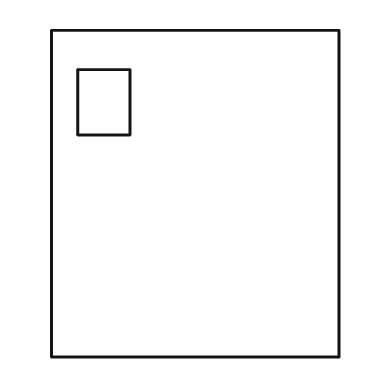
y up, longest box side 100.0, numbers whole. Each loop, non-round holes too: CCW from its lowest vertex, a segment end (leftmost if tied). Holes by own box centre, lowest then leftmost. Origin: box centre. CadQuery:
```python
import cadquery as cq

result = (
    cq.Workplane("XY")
    .moveTo(-44.0, -50.0)
    .lineTo(44.0, -50.0)
    .lineTo(44.0, 50.0)
    .lineTo(-44.0, 50.0)
    .close()
    .moveTo(-36.0, 18.0)
    .lineTo(-20.0, 18.0)
    .lineTo(-20.0, 38.0)
    .lineTo(-36.0, 38.0)
    .close()
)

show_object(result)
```